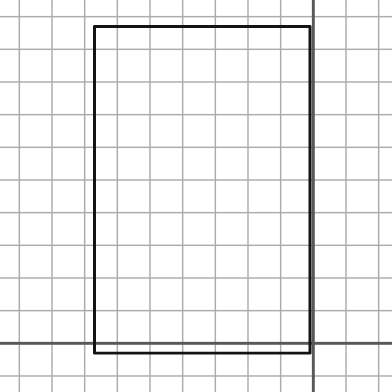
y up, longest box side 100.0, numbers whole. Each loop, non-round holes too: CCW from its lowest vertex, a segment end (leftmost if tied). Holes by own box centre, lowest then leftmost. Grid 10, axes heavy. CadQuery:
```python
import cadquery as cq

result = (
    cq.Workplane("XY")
    .moveTo(-67.0, -3.0)
    .lineTo(-1.0, -3.0)
    .lineTo(-1.0, 97.0)
    .lineTo(-67.0, 97.0)
    .close()
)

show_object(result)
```